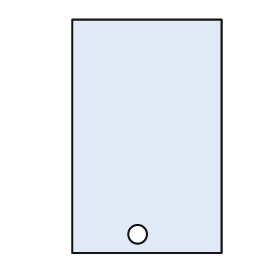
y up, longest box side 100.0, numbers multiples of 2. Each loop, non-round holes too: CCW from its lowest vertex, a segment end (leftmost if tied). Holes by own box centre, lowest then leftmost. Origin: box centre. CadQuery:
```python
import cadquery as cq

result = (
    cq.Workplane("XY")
    .moveTo(-32.0, -50.0)
    .lineTo(32.0, -50.0)
    .lineTo(32.0, 50.0)
    .lineTo(-32.0, 50.0)
    .close()
    .moveTo(-4.0, -42.0)
    .circle(4.0)
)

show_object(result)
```